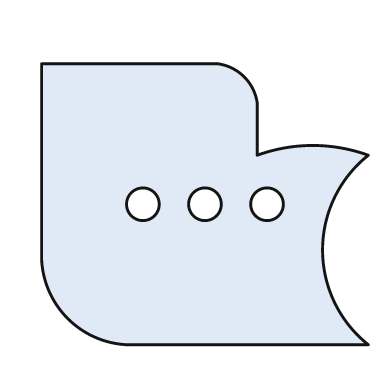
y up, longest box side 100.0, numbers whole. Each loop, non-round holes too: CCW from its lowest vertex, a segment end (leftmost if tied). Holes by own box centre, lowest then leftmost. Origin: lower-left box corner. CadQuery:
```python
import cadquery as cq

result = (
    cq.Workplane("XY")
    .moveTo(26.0, 0.0)
    .lineTo(100.0, 0.0)
    .threePointArc((86.0, 29.0), (100.0, 58.0))
    .threePointArc((83.0, 61.0), (66.0, 58.0))
    .lineTo(66.0, 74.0)
    .threePointArc((62.0, 82.0), (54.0, 86.0))
    .lineTo(0.0, 86.0)
    .lineTo(0.0, 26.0)
    .threePointArc((8.0, 8.0), (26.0, 0.0))
    .close()
    .moveTo(31.0, 43.0)
    .circle(5.0)
    .moveTo(50.0, 43.0)
    .circle(5.0)
    .moveTo(69.0, 43.0)
    .circle(5.0)
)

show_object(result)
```